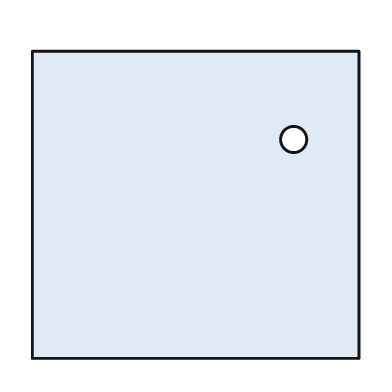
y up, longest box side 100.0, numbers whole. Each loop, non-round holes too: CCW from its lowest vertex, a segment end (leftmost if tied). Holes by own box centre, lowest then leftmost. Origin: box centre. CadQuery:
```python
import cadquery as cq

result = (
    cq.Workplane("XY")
    .moveTo(-50.0, -47.0)
    .lineTo(50.0, -47.0)
    .lineTo(50.0, 47.0)
    .lineTo(-50.0, 47.0)
    .close()
    .moveTo(30.0, 20.0)
    .circle(4.0)
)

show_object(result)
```